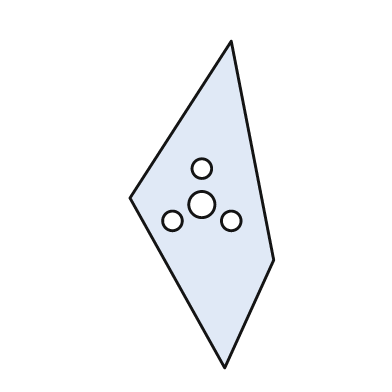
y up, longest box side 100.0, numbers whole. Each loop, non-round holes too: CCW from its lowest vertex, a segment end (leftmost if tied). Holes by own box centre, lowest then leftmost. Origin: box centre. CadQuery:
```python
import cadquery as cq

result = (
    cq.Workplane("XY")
    .moveTo(7.0, -50.0)
    .lineTo(22.0, -17.0)
    .lineTo(9.0, 50.0)
    .lineTo(-22.0, 2.0)
    .close()
    .moveTo(-9.0, -5.0)
    .circle(3.0)
    .moveTo(9.0, -5.0)
    .circle(3.0)
    .moveTo(0.0, 0.0)
    .circle(4.0)
    .moveTo(0.0, 11.0)
    .circle(3.0)
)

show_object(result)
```